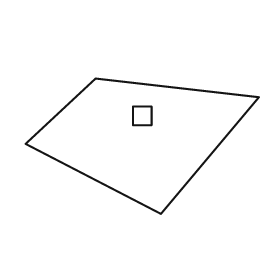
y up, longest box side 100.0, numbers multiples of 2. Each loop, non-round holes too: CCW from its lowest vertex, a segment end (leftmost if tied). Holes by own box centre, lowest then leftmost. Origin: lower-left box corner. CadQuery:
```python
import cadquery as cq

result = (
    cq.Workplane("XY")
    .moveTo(58.0, 0.0)
    .lineTo(100.0, 50.0)
    .lineTo(30.0, 58.0)
    .lineTo(0.0, 30.0)
    .close()
    .moveTo(46.0, 38.0)
    .lineTo(54.0, 38.0)
    .lineTo(54.0, 46.0)
    .lineTo(46.0, 46.0)
    .close()
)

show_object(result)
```